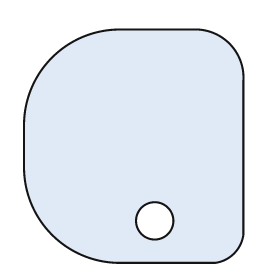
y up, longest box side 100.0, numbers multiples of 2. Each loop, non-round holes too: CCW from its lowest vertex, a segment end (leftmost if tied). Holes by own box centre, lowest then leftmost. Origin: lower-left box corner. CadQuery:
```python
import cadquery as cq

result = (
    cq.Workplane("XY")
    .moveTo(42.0, 0.0)
    .lineTo(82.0, 0.0)
    .threePointArc((90.0, 4.0), (94.0, 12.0))
    .lineTo(94.0, 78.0)
    .threePointArc((88.0, 94.0), (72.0, 100.0))
    .lineTo(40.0, 100.0)
    .threePointArc((12.0, 88.0), (0.0, 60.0))
    .lineTo(0.0, 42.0)
    .threePointArc((12.0, 12.0), (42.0, 0.0))
    .close()
    .moveTo(56.0, 18.0)
    .circle(8.0)
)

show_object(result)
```